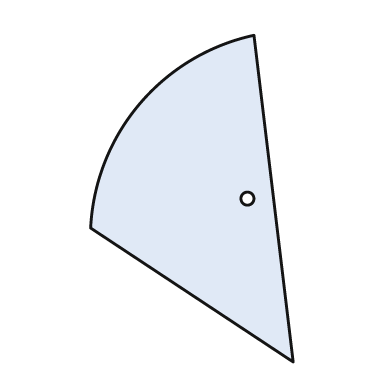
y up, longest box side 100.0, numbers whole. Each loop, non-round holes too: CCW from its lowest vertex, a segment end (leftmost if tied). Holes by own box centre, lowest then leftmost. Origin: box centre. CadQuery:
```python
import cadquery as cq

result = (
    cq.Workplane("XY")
    .moveTo(31.0, -50.0)
    .lineTo(19.0, 50.0)
    .threePointArc((-16.0, 29.0), (-31.0, -9.0))
    .close()
    .moveTo(17.0, 0.0)
    .circle(2.0)
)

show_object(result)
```